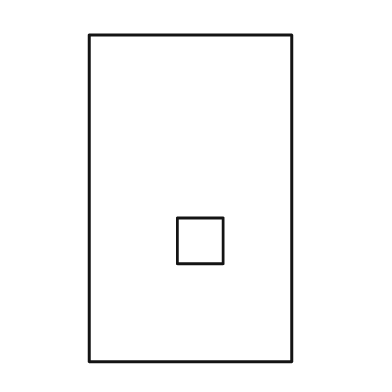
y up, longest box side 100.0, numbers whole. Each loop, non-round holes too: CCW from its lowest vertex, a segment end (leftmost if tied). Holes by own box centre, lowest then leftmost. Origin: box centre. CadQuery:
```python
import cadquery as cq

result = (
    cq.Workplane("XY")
    .moveTo(-31.0, -50.0)
    .lineTo(31.0, -50.0)
    .lineTo(31.0, 50.0)
    .lineTo(-31.0, 50.0)
    .close()
    .moveTo(-4.0, -20.0)
    .lineTo(10.0, -20.0)
    .lineTo(10.0, -6.0)
    .lineTo(-4.0, -6.0)
    .close()
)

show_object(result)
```